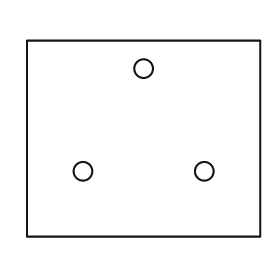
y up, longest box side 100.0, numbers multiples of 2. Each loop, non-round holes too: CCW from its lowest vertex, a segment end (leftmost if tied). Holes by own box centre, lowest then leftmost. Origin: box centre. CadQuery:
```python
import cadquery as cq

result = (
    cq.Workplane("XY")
    .moveTo(-50.0, -42.0)
    .lineTo(50.0, -42.0)
    .lineTo(50.0, 42.0)
    .lineTo(-50.0, 42.0)
    .close()
    .moveTo(-26.0, -14.0)
    .circle(4.0)
    .moveTo(26.0, -14.0)
    .circle(4.0)
    .moveTo(0.0, 30.0)
    .circle(4.0)
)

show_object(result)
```